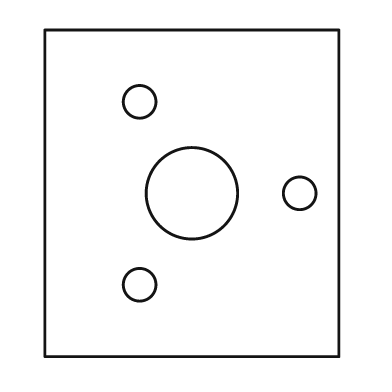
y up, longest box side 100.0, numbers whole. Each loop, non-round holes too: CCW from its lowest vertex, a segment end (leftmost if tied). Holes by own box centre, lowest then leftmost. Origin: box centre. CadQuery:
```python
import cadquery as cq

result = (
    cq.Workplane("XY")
    .moveTo(-45.0, -50.0)
    .lineTo(45.0, -50.0)
    .lineTo(45.0, 50.0)
    .lineTo(-45.0, 50.0)
    .close()
    .moveTo(-16.0, -28.0)
    .circle(5.0)
    .moveTo(0.0, 0.0)
    .circle(14.0)
    .moveTo(33.0, 0.0)
    .circle(5.0)
    .moveTo(-16.0, 28.0)
    .circle(5.0)
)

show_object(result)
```